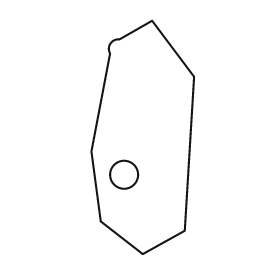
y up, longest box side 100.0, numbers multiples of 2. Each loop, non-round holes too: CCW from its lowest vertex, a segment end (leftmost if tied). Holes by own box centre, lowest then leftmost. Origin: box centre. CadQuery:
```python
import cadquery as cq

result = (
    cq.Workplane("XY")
    .moveTo(0.0, -50.0)
    .lineTo(18.0, -40.0)
    .lineTo(22.0, 26.0)
    .lineTo(4.0, 50.0)
    .lineTo(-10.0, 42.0)
    .threePointArc((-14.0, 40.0), (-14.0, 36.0))
    .lineTo(-22.0, -6.0)
    .lineTo(-18.0, -36.0)
    .close()
    .moveTo(-8.0, -16.0)
    .circle(6.0)
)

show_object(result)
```